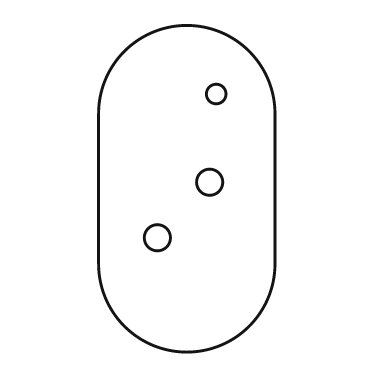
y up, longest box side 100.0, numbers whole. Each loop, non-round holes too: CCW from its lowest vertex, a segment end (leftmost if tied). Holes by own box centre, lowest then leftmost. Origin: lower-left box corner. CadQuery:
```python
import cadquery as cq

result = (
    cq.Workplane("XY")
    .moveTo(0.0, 27.0)
    .threePointArc((27.0, 0.0), (54.0, 27.0))
    .lineTo(54.0, 73.0)
    .threePointArc((27.0, 100.0), (0.0, 73.0))
    .close()
    .moveTo(18.0, 35.0)
    .circle(4.0)
    .moveTo(34.0, 52.0)
    .circle(4.0)
    .moveTo(36.0, 79.0)
    .circle(3.0)
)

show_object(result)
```